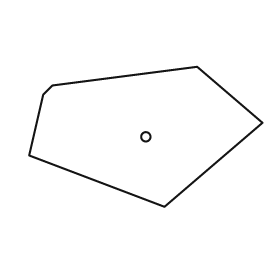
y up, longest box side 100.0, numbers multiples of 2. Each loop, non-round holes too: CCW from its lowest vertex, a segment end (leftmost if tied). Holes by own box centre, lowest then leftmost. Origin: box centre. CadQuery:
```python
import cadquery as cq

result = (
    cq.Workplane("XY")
    .moveTo(8.0, -30.0)
    .lineTo(50.0, 6.0)
    .lineTo(22.0, 30.0)
    .lineTo(-40.0, 22.0)
    .lineTo(-44.0, 18.0)
    .lineTo(-50.0, -8.0)
    .close()
    .moveTo(0.0, 0.0)
    .circle(2.0)
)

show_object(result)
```